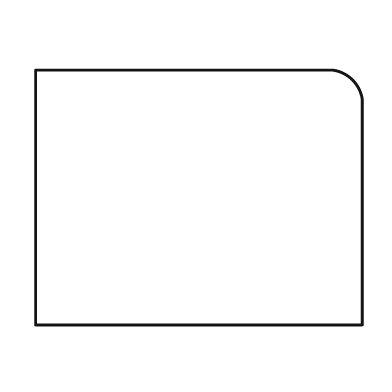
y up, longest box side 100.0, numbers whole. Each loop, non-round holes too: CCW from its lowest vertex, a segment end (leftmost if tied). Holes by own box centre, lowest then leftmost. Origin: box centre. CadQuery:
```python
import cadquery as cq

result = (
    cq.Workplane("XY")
    .moveTo(-50.0, -39.0)
    .lineTo(50.0, -39.0)
    .lineTo(50.0, 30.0)
    .threePointArc((47.0, 36.0), (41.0, 39.0))
    .lineTo(-50.0, 39.0)
    .close()
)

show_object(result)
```